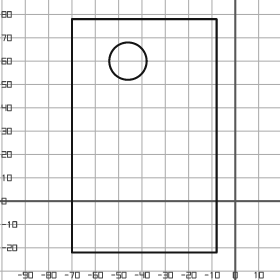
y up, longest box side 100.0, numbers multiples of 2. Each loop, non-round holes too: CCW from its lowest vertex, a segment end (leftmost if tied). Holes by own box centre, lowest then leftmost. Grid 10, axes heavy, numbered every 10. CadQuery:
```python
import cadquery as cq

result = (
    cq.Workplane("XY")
    .moveTo(-70.0, -22.0)
    .lineTo(-8.0, -22.0)
    .lineTo(-8.0, 78.0)
    .lineTo(-70.0, 78.0)
    .close()
    .moveTo(-46.0, 60.0)
    .circle(8.0)
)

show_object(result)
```